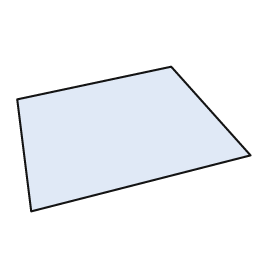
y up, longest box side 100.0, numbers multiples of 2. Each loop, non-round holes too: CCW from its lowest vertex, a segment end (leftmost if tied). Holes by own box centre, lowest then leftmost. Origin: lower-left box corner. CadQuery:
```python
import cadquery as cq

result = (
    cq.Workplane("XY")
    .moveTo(6.0, 0.0)
    .lineTo(100.0, 24.0)
    .lineTo(66.0, 62.0)
    .lineTo(0.0, 48.0)
    .close()
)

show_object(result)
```